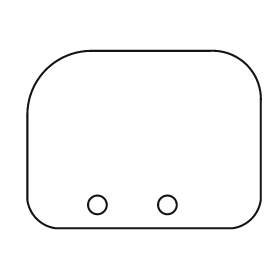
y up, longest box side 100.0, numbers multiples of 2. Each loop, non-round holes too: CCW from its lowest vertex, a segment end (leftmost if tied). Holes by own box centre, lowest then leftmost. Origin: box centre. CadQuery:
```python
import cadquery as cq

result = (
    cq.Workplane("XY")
    .moveTo(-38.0, -38.0)
    .lineTo(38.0, -38.0)
    .threePointArc((46.0, -34.0), (50.0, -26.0))
    .lineTo(50.0, 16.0)
    .threePointArc((44.0, 32.0), (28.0, 38.0))
    .lineTo(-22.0, 38.0)
    .threePointArc((-42.0, 30.0), (-50.0, 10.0))
    .lineTo(-50.0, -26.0)
    .threePointArc((-46.0, -34.0), (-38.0, -38.0))
    .close()
    .moveTo(-20.0, -28.0)
    .circle(4.0)
    .moveTo(10.0, -28.0)
    .circle(4.0)
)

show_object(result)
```